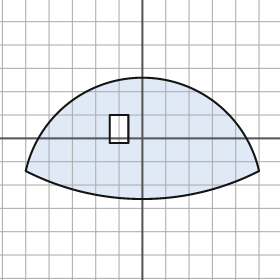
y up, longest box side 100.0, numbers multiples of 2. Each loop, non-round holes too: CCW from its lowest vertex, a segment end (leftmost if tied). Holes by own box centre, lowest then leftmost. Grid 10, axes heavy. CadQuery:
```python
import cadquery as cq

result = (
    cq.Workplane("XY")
    .moveTo(-50.0, -14.0)
    .threePointArc((0.0, -26.0), (50.0, -14.0))
    .threePointArc((0.0, 26.0), (-50.0, -14.0))
    .close()
    .moveTo(-14.0, -2.0)
    .lineTo(-6.0, -2.0)
    .lineTo(-6.0, 10.0)
    .lineTo(-14.0, 10.0)
    .close()
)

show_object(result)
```